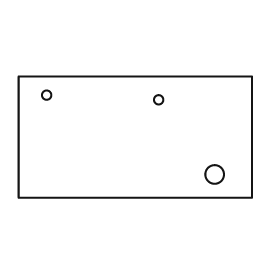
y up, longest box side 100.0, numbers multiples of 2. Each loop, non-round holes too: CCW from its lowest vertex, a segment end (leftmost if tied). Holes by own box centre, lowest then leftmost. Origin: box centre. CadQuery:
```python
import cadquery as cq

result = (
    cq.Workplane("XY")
    .moveTo(-50.0, -26.0)
    .lineTo(50.0, -26.0)
    .lineTo(50.0, 26.0)
    .lineTo(-50.0, 26.0)
    .close()
    .moveTo(34.0, -16.0)
    .circle(4.0)
    .moveTo(10.0, 16.0)
    .circle(2.0)
    .moveTo(-38.0, 18.0)
    .circle(2.0)
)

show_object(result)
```